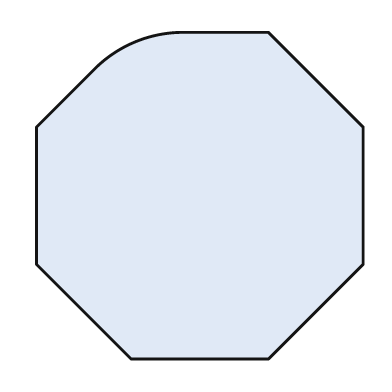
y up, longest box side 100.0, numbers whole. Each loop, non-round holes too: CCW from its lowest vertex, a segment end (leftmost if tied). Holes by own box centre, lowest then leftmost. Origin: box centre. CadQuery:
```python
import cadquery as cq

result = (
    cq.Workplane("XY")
    .moveTo(-21.0, -50.0)
    .lineTo(21.0, -50.0)
    .lineTo(50.0, -21.0)
    .lineTo(50.0, 21.0)
    .lineTo(21.0, 50.0)
    .lineTo(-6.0, 50.0)
    .threePointArc((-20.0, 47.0), (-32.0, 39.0))
    .lineTo(-50.0, 21.0)
    .lineTo(-50.0, -21.0)
    .close()
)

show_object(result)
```